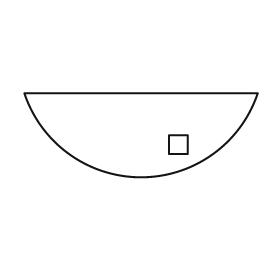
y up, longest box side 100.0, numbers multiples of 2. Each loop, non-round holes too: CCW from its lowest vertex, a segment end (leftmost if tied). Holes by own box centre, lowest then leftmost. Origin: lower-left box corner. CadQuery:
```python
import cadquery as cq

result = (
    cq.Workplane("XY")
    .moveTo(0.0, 36.0)
    .threePointArc((50.0, 0.0), (100.0, 36.0))
    .close()
    .moveTo(62.0, 10.0)
    .lineTo(70.0, 10.0)
    .lineTo(70.0, 18.0)
    .lineTo(62.0, 18.0)
    .close()
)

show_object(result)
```